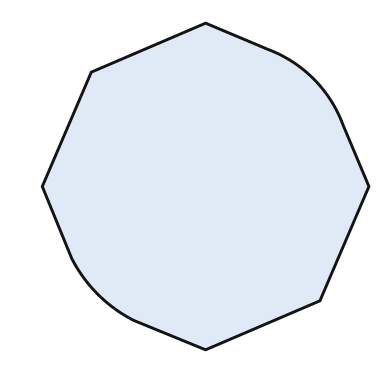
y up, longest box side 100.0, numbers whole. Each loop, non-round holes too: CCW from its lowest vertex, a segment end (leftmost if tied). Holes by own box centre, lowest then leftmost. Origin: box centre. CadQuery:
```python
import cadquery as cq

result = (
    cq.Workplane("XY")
    .moveTo(0.0, -50.0)
    .lineTo(35.0, -35.0)
    .lineTo(50.0, 0.0)
    .lineTo(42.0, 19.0)
    .threePointArc((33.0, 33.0), (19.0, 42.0))
    .lineTo(0.0, 50.0)
    .lineTo(-35.0, 35.0)
    .lineTo(-50.0, 0.0)
    .lineTo(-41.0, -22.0)
    .threePointArc((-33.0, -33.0), (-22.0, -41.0))
    .close()
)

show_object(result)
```